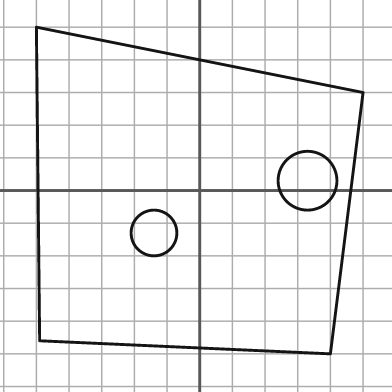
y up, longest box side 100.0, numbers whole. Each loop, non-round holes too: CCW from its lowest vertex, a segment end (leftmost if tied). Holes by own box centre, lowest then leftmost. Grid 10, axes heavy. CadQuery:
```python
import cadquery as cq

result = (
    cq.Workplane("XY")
    .moveTo(40.0, -50.0)
    .lineTo(50.0, 30.0)
    .lineTo(-50.0, 50.0)
    .lineTo(-49.0, -46.0)
    .close()
    .moveTo(-14.0, -13.0)
    .circle(7.0)
    .moveTo(33.0, 3.0)
    .circle(9.0)
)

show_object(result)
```